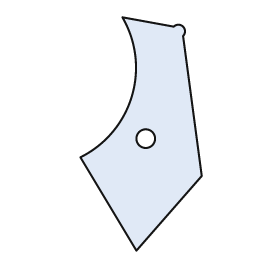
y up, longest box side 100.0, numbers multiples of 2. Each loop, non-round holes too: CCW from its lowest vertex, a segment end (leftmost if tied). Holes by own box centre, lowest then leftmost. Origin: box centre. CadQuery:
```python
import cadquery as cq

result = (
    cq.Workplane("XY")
    .moveTo(-2.0, -50.0)
    .lineTo(26.0, -18.0)
    .lineTo(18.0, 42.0)
    .threePointArc((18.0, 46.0), (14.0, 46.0))
    .lineTo(-8.0, 50.0)
    .threePointArc((-4.0, 16.0), (-26.0, -10.0))
    .close()
    .moveTo(2.0, -2.0)
    .circle(4.0)
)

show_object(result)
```